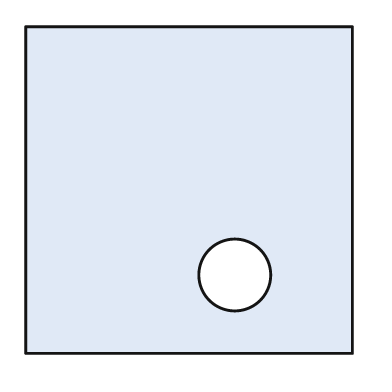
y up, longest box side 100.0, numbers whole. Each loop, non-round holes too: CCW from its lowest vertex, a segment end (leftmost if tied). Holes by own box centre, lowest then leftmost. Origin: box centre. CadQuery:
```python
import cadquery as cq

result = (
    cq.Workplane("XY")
    .moveTo(-50.0, -50.0)
    .lineTo(50.0, -50.0)
    .lineTo(50.0, 50.0)
    .lineTo(-50.0, 50.0)
    .close()
    .moveTo(14.0, -26.0)
    .circle(11.0)
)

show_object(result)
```